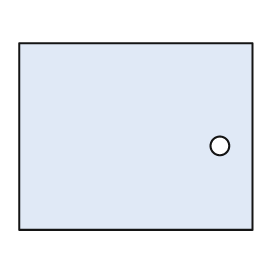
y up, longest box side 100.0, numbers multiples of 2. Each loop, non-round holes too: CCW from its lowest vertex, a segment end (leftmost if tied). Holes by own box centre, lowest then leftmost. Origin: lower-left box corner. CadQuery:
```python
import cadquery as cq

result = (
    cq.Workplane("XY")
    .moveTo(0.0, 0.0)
    .lineTo(100.0, 0.0)
    .lineTo(100.0, 80.0)
    .lineTo(0.0, 80.0)
    .close()
    .moveTo(86.0, 36.0)
    .circle(4.0)
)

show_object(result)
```